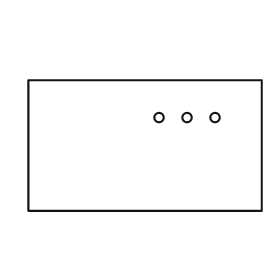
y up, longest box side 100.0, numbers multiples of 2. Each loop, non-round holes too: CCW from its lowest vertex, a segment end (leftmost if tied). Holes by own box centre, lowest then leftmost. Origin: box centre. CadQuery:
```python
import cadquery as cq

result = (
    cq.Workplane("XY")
    .moveTo(-50.0, -28.0)
    .lineTo(50.0, -28.0)
    .lineTo(50.0, 28.0)
    .lineTo(-50.0, 28.0)
    .close()
    .moveTo(6.0, 12.0)
    .circle(2.0)
    .moveTo(18.0, 12.0)
    .circle(2.0)
    .moveTo(30.0, 12.0)
    .circle(2.0)
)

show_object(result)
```